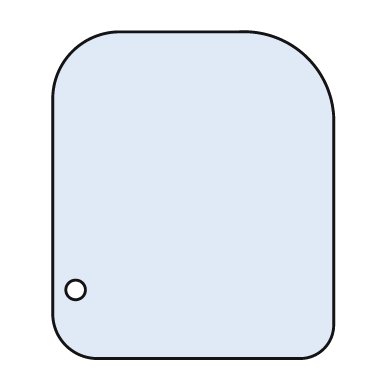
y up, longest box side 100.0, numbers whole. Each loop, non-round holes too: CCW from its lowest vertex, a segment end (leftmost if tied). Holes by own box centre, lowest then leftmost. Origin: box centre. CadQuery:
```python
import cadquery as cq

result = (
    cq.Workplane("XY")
    .moveTo(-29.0, -50.0)
    .lineTo(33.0, -50.0)
    .threePointArc((40.0, -47.0), (43.0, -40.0))
    .lineTo(43.0, 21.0)
    .threePointArc((35.0, 42.0), (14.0, 50.0))
    .lineTo(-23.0, 50.0)
    .threePointArc((-37.0, 44.0), (-43.0, 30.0))
    .lineTo(-43.0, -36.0)
    .threePointArc((-39.0, -46.0), (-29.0, -50.0))
    .close()
    .moveTo(-36.0, -29.0)
    .circle(3.0)
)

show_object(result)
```